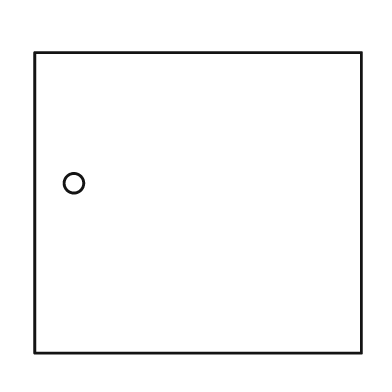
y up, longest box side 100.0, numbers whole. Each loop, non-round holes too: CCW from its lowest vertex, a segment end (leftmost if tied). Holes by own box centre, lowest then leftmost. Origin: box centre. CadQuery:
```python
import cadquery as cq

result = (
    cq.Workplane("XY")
    .moveTo(-50.0, -46.0)
    .lineTo(50.0, -46.0)
    .lineTo(50.0, 46.0)
    .lineTo(-50.0, 46.0)
    .close()
    .moveTo(-38.0, 6.0)
    .circle(3.0)
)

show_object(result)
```